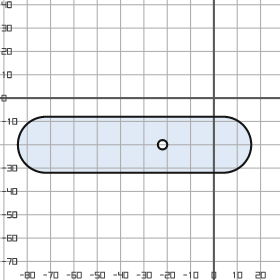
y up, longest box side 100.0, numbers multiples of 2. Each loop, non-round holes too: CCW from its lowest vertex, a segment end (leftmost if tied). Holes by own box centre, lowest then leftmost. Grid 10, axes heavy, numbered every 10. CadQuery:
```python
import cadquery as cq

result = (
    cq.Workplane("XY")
    .moveTo(-72.0, -32.0)
    .lineTo(4.0, -32.0)
    .threePointArc((16.0, -20.0), (4.0, -8.0))
    .lineTo(-72.0, -8.0)
    .threePointArc((-84.0, -20.0), (-72.0, -32.0))
    .close()
    .moveTo(-22.0, -20.0)
    .circle(2.0)
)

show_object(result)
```